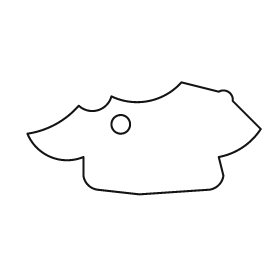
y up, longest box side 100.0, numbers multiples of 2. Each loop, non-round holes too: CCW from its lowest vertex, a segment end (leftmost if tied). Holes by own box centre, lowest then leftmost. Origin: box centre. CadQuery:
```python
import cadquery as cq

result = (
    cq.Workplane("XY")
    .moveTo(-2.0, -24.0)
    .lineTo(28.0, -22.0)
    .threePointArc((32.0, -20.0), (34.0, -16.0))
    .lineTo(32.0, -8.0)
    .threePointArc((42.0, -4.0), (50.0, 4.0))
    .lineTo(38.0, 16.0)
    .threePointArc((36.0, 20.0), (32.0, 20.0))
    .lineTo(16.0, 24.0)
    .threePointArc((2.0, 16.0), (-14.0, 18.0))
    .threePointArc((-20.0, 12.0), (-28.0, 14.0))
    .threePointArc((-38.0, 6.0), (-50.0, 2.0))
    .threePointArc((-40.0, -8.0), (-26.0, -8.0))
    .lineTo(-26.0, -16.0)
    .threePointArc((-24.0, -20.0), (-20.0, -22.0))
    .close()
    .moveTo(-10.0, 6.0)
    .circle(4.0)
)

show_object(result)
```